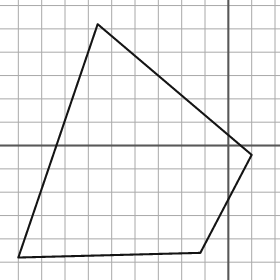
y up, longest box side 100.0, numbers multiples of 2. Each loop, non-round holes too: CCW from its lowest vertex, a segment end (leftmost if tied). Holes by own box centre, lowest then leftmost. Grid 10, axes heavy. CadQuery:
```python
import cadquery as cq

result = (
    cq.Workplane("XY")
    .moveTo(-90.0, -48.0)
    .lineTo(-12.0, -46.0)
    .lineTo(10.0, -4.0)
    .lineTo(-56.0, 52.0)
    .close()
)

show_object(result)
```